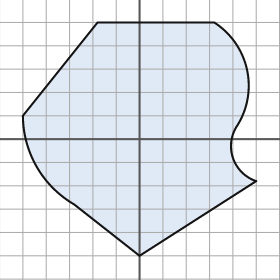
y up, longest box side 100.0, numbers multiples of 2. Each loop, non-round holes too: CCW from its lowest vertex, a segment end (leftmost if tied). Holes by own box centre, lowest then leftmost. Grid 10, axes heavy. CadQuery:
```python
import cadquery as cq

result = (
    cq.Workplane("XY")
    .moveTo(0.0, -50.0)
    .lineTo(50.0, -18.0)
    .threePointArc((40.0, -8.0), (42.0, 6.0))
    .threePointArc((46.0, 30.0), (32.0, 50.0))
    .lineTo(-18.0, 50.0)
    .lineTo(-50.0, 10.0)
    .threePointArc((-44.0, -12.0), (-28.0, -28.0))
    .close()
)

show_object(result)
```